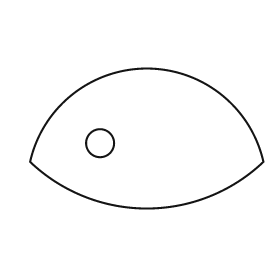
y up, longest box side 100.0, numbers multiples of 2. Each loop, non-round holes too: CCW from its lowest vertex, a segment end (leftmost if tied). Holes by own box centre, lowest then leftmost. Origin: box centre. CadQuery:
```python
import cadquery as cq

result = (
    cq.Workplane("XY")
    .moveTo(-50.0, -10.0)
    .threePointArc((0.0, -30.0), (50.0, -10.0))
    .threePointArc((0.0, 30.0), (-50.0, -10.0))
    .close()
    .moveTo(-20.0, -2.0)
    .circle(6.0)
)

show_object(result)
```